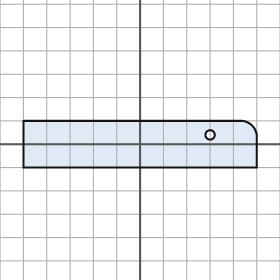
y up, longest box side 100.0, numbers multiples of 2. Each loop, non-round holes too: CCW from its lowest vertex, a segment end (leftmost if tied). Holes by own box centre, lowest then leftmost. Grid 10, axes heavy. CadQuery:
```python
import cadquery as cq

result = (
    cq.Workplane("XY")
    .moveTo(-50.0, -10.0)
    .lineTo(50.0, -10.0)
    .lineTo(50.0, 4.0)
    .threePointArc((48.0, 8.0), (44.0, 10.0))
    .lineTo(-50.0, 10.0)
    .close()
    .moveTo(30.0, 4.0)
    .circle(2.0)
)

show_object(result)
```